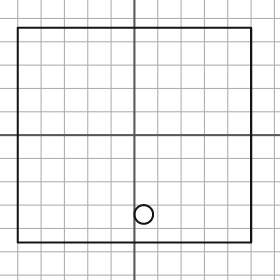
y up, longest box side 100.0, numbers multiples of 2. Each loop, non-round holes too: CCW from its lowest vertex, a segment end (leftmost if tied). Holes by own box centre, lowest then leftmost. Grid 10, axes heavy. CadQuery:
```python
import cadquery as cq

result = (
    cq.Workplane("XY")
    .moveTo(-50.0, -46.0)
    .lineTo(50.0, -46.0)
    .lineTo(50.0, 46.0)
    .lineTo(-50.0, 46.0)
    .close()
    .moveTo(4.0, -34.0)
    .circle(4.0)
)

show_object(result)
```